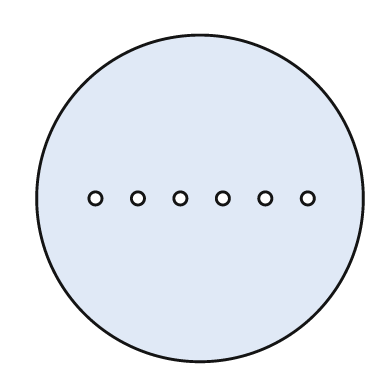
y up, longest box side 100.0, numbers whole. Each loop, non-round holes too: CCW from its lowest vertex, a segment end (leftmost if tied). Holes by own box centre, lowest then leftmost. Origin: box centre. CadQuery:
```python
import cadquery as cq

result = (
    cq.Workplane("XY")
    .moveTo(0.0, 0.0)
    .circle(50.0)
    .moveTo(-32.0, 0.0)
    .circle(2.0)
    .moveTo(-19.0, 0.0)
    .circle(2.0)
    .moveTo(-6.0, 0.0)
    .circle(2.0)
    .moveTo(7.0, 0.0)
    .circle(2.0)
    .moveTo(20.0, 0.0)
    .circle(2.0)
    .moveTo(33.0, 0.0)
    .circle(2.0)
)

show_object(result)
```